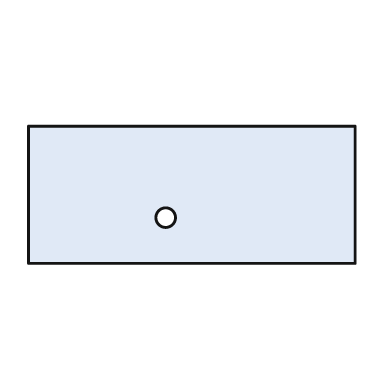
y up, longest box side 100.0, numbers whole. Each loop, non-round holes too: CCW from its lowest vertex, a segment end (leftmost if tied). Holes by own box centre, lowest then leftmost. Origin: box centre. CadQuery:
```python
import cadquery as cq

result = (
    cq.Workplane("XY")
    .moveTo(-50.0, -21.0)
    .lineTo(50.0, -21.0)
    .lineTo(50.0, 21.0)
    .lineTo(-50.0, 21.0)
    .close()
    .moveTo(-8.0, -7.0)
    .circle(3.0)
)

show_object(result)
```